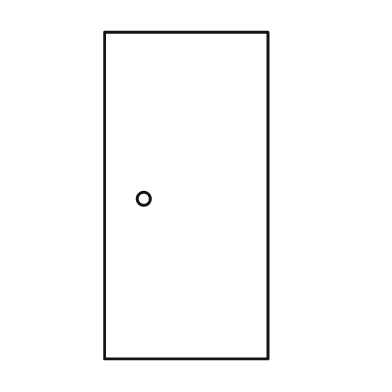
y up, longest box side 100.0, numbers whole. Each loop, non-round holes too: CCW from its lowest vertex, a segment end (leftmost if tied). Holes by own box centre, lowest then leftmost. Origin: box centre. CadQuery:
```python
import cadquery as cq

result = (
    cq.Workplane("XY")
    .moveTo(-25.0, -50.0)
    .lineTo(25.0, -50.0)
    .lineTo(25.0, 50.0)
    .lineTo(-25.0, 50.0)
    .close()
    .moveTo(-13.0, -1.0)
    .circle(2.0)
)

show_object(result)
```